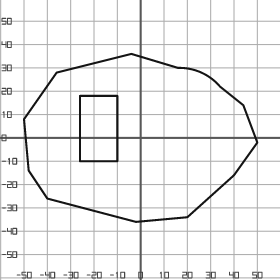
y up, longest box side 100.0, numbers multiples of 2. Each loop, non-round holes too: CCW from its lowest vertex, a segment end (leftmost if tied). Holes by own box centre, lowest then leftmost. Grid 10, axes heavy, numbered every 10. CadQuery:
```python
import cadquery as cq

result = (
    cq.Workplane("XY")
    .moveTo(-2.0, -36.0)
    .lineTo(20.0, -34.0)
    .lineTo(40.0, -16.0)
    .lineTo(50.0, -2.0)
    .lineTo(44.0, 14.0)
    .lineTo(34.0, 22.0)
    .threePointArc((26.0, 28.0), (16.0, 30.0))
    .lineTo(-4.0, 36.0)
    .lineTo(-36.0, 28.0)
    .lineTo(-50.0, 8.0)
    .lineTo(-48.0, -14.0)
    .lineTo(-40.0, -26.0)
    .close()
    .moveTo(-26.0, -10.0)
    .lineTo(-10.0, -10.0)
    .lineTo(-10.0, 18.0)
    .lineTo(-26.0, 18.0)
    .close()
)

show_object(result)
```